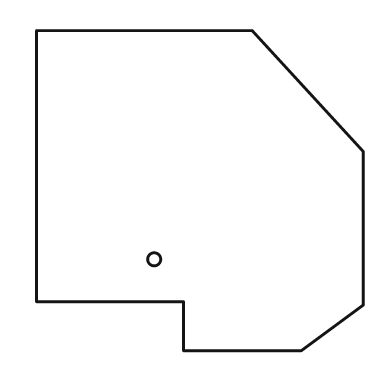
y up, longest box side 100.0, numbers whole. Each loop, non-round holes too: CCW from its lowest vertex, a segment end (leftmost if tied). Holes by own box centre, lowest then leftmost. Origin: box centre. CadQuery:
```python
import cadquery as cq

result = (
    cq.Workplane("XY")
    .moveTo(-5.0, -49.0)
    .lineTo(31.0, -49.0)
    .lineTo(50.0, -35.0)
    .lineTo(50.0, 12.0)
    .lineTo(16.0, 49.0)
    .lineTo(-50.0, 49.0)
    .lineTo(-50.0, -34.0)
    .lineTo(-5.0, -34.0)
    .close()
    .moveTo(-14.0, -21.0)
    .circle(2.0)
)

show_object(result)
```